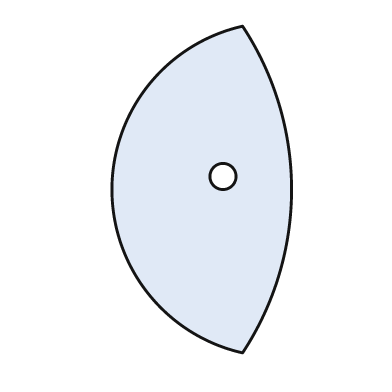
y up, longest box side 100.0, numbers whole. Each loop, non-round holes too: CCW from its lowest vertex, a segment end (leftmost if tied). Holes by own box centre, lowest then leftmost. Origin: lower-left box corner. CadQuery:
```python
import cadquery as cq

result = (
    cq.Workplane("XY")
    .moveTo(40.0, 0.0)
    .threePointArc((55.0, 50.0), (40.0, 100.0))
    .threePointArc((0.0, 50.0), (40.0, 0.0))
    .close()
    .moveTo(34.0, 54.0)
    .circle(4.0)
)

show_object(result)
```